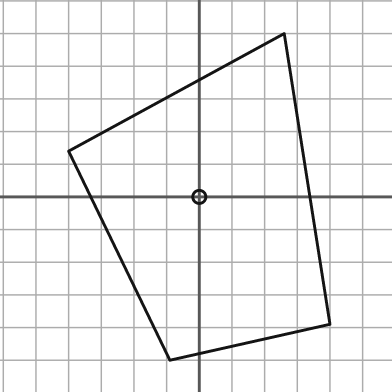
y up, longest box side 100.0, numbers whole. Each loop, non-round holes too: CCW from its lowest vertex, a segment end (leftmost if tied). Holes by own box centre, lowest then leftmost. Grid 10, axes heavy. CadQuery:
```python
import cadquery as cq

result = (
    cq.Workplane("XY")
    .moveTo(-9.0, -50.0)
    .lineTo(40.0, -39.0)
    .lineTo(26.0, 50.0)
    .lineTo(-40.0, 14.0)
    .close()
    .moveTo(0.0, 0.0)
    .circle(2.0)
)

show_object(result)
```